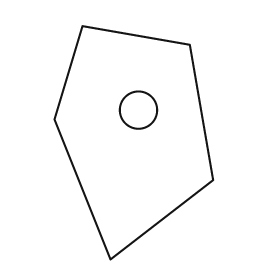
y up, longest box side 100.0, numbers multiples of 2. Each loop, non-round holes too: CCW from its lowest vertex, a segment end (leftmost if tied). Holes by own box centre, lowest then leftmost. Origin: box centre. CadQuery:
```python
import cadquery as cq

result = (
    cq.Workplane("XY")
    .moveTo(-10.0, -50.0)
    .lineTo(34.0, -16.0)
    .lineTo(24.0, 42.0)
    .lineTo(-22.0, 50.0)
    .lineTo(-34.0, 10.0)
    .close()
    .moveTo(2.0, 14.0)
    .circle(8.0)
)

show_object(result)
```